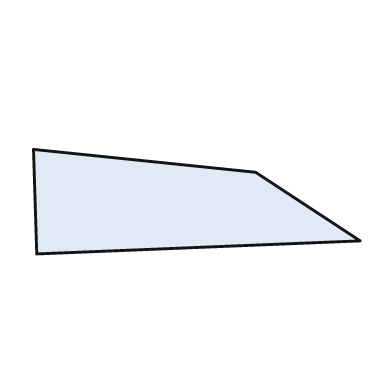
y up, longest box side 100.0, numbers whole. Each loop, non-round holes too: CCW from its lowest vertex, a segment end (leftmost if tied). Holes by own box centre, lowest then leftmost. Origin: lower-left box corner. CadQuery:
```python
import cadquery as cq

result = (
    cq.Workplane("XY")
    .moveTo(1.0, 0.0)
    .lineTo(100.0, 4.0)
    .lineTo(68.0, 25.0)
    .lineTo(0.0, 32.0)
    .close()
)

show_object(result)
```